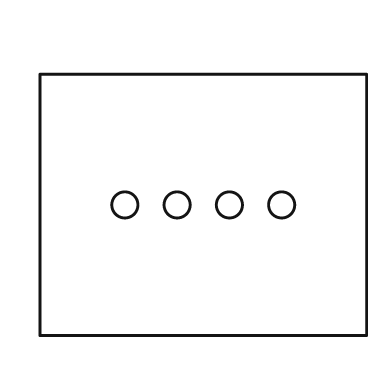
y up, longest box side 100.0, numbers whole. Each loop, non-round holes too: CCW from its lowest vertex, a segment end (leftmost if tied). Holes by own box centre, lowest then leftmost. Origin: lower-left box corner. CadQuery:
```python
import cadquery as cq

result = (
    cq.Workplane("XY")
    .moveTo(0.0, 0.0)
    .lineTo(100.0, 0.0)
    .lineTo(100.0, 80.0)
    .lineTo(0.0, 80.0)
    .close()
    .moveTo(26.0, 40.0)
    .circle(4.0)
    .moveTo(42.0, 40.0)
    .circle(4.0)
    .moveTo(58.0, 40.0)
    .circle(4.0)
    .moveTo(74.0, 40.0)
    .circle(4.0)
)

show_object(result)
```